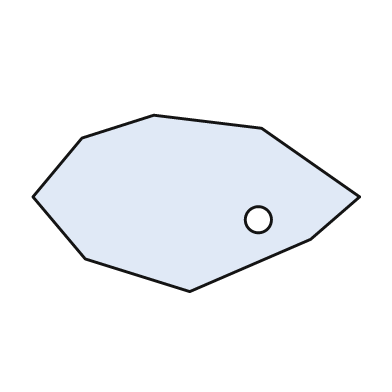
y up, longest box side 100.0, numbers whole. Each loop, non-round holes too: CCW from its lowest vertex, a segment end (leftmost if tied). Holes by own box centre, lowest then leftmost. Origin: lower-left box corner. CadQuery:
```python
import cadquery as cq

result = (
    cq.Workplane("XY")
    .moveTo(48.0, 0.0)
    .lineTo(85.0, 16.0)
    .lineTo(100.0, 29.0)
    .lineTo(70.0, 50.0)
    .lineTo(37.0, 54.0)
    .lineTo(15.0, 47.0)
    .lineTo(0.0, 29.0)
    .lineTo(16.0, 10.0)
    .close()
    .moveTo(69.0, 22.0)
    .circle(4.0)
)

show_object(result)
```